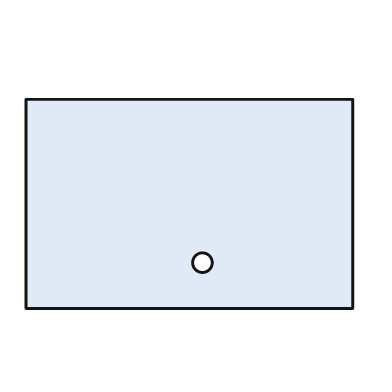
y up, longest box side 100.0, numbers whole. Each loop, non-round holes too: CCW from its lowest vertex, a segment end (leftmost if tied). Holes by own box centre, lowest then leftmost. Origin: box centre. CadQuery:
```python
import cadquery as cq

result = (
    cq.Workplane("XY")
    .moveTo(-50.0, -32.0)
    .lineTo(50.0, -32.0)
    .lineTo(50.0, 32.0)
    .lineTo(-50.0, 32.0)
    .close()
    .moveTo(4.0, -18.0)
    .circle(3.0)
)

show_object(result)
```